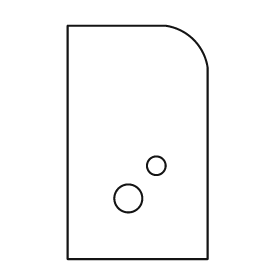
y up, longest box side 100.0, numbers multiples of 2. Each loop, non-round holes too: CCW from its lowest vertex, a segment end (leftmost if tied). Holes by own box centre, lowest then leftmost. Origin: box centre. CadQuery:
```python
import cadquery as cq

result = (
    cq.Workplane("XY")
    .moveTo(-30.0, -50.0)
    .lineTo(30.0, -50.0)
    .lineTo(30.0, 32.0)
    .threePointArc((24.0, 44.0), (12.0, 50.0))
    .lineTo(-30.0, 50.0)
    .close()
    .moveTo(-4.0, -24.0)
    .circle(6.0)
    .moveTo(8.0, -10.0)
    .circle(4.0)
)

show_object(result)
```